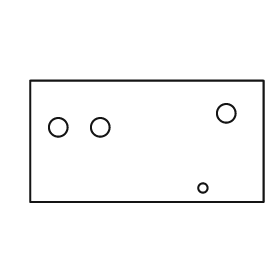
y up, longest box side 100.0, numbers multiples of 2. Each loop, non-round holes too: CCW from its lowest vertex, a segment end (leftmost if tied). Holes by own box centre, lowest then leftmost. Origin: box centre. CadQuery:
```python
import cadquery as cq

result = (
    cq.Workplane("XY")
    .moveTo(-50.0, -26.0)
    .lineTo(50.0, -26.0)
    .lineTo(50.0, 26.0)
    .lineTo(-50.0, 26.0)
    .close()
    .moveTo(24.0, -20.0)
    .circle(2.0)
    .moveTo(-38.0, 6.0)
    .circle(4.0)
    .moveTo(-20.0, 6.0)
    .circle(4.0)
    .moveTo(34.0, 12.0)
    .circle(4.0)
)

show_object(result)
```